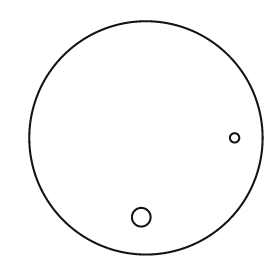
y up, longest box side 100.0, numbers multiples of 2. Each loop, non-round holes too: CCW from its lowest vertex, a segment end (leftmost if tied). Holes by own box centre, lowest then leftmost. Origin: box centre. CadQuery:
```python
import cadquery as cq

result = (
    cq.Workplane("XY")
    .moveTo(0.0, 0.0)
    .circle(50.0)
    .moveTo(-2.0, -34.0)
    .circle(4.0)
    .moveTo(38.0, 0.0)
    .circle(2.0)
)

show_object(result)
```